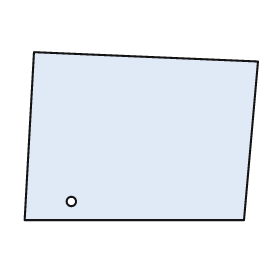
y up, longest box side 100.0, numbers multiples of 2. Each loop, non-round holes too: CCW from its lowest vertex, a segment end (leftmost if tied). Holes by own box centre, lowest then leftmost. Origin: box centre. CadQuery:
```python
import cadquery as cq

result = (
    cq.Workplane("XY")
    .moveTo(-50.0, -36.0)
    .lineTo(44.0, -36.0)
    .lineTo(50.0, 32.0)
    .lineTo(-46.0, 36.0)
    .close()
    .moveTo(-30.0, -28.0)
    .circle(2.0)
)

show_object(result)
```